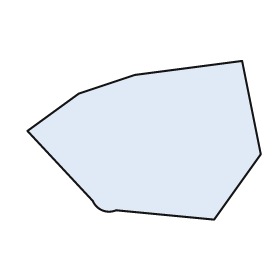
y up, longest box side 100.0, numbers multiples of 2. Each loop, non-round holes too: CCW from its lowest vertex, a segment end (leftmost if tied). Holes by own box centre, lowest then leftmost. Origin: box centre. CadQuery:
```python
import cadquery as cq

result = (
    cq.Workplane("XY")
    .moveTo(30.0, -34.0)
    .lineTo(50.0, -6.0)
    .lineTo(42.0, 34.0)
    .lineTo(-4.0, 28.0)
    .lineTo(-28.0, 20.0)
    .lineTo(-50.0, 4.0)
    .lineTo(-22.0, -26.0)
    .threePointArc((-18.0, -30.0), (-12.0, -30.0))
    .close()
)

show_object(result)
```